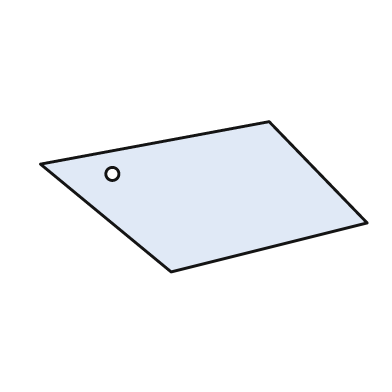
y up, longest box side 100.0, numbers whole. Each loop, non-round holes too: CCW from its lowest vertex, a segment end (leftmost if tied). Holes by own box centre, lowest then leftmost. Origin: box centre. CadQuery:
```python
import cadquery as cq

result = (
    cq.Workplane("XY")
    .moveTo(-10.0, -23.0)
    .lineTo(50.0, -8.0)
    .lineTo(20.0, 23.0)
    .lineTo(-50.0, 10.0)
    .close()
    .moveTo(-28.0, 7.0)
    .circle(2.0)
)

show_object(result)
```